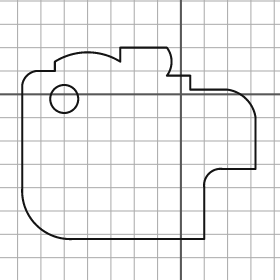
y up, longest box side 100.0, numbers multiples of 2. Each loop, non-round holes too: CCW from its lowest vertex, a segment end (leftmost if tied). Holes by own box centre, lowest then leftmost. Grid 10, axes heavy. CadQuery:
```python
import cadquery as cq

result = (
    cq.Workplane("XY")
    .moveTo(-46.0, -62.0)
    .lineTo(10.0, -62.0)
    .lineTo(10.0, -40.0)
    .threePointArc((12.0, -34.0), (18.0, -32.0))
    .lineTo(32.0, -32.0)
    .lineTo(32.0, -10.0)
    .threePointArc((28.0, -2.0), (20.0, 2.0))
    .lineTo(4.0, 2.0)
    .lineTo(4.0, 8.0)
    .lineTo(-6.0, 8.0)
    .threePointArc((-4.0, 14.0), (-6.0, 20.0))
    .lineTo(-26.0, 20.0)
    .lineTo(-26.0, 14.0)
    .threePointArc((-40.0, 18.0), (-54.0, 14.0))
    .lineTo(-54.0, 10.0)
    .lineTo(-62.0, 10.0)
    .threePointArc((-66.0, 8.0), (-68.0, 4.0))
    .lineTo(-68.0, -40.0)
    .threePointArc((-62.0, -56.0), (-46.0, -62.0))
    .close()
    .moveTo(-50.0, -2.0)
    .circle(6.0)
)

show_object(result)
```